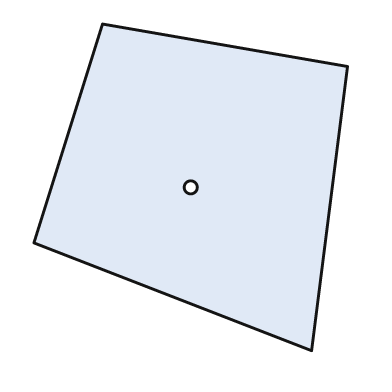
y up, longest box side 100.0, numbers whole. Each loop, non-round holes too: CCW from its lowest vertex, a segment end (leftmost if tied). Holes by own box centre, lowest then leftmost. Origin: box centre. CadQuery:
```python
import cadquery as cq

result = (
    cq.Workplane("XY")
    .moveTo(37.0, -50.0)
    .lineTo(48.0, 37.0)
    .lineTo(-27.0, 50.0)
    .lineTo(-48.0, -17.0)
    .close()
    .moveTo(0.0, 0.0)
    .circle(2.0)
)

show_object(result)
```